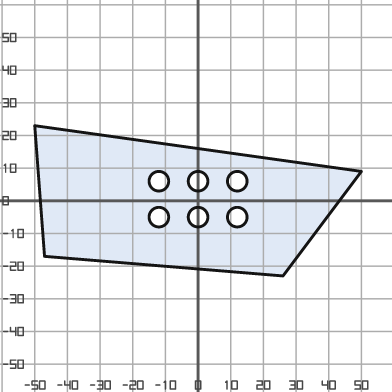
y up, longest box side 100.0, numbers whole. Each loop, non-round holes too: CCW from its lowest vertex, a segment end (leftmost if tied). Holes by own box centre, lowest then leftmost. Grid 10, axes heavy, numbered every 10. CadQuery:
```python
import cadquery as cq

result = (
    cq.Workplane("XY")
    .moveTo(26.0, -23.0)
    .lineTo(50.0, 9.0)
    .lineTo(-50.0, 23.0)
    .lineTo(-47.0, -17.0)
    .close()
    .moveTo(-12.0, -5.0)
    .circle(3.0)
    .moveTo(0.0, -5.0)
    .circle(3.0)
    .moveTo(12.0, -5.0)
    .circle(3.0)
    .moveTo(-12.0, 6.0)
    .circle(3.0)
    .moveTo(0.0, 6.0)
    .circle(3.0)
    .moveTo(12.0, 6.0)
    .circle(3.0)
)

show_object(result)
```